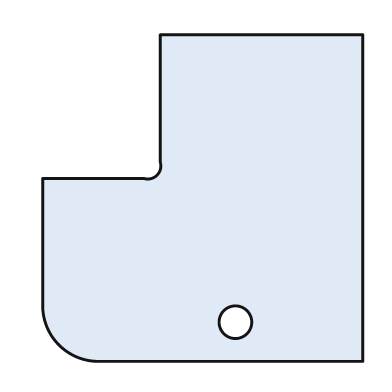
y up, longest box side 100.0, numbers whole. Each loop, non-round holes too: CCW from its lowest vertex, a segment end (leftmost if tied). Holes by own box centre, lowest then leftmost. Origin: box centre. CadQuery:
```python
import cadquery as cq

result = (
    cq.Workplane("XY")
    .moveTo(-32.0, -50.0)
    .lineTo(49.0, -50.0)
    .lineTo(49.0, 50.0)
    .lineTo(-13.0, 50.0)
    .lineTo(-13.0, 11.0)
    .threePointArc((-14.0, 7.0), (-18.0, 6.0))
    .lineTo(-49.0, 6.0)
    .lineTo(-49.0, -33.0)
    .threePointArc((-44.0, -45.0), (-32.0, -50.0))
    .close()
    .moveTo(10.0, -38.0)
    .circle(5.0)
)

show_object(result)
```